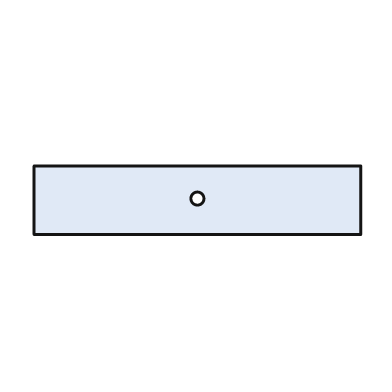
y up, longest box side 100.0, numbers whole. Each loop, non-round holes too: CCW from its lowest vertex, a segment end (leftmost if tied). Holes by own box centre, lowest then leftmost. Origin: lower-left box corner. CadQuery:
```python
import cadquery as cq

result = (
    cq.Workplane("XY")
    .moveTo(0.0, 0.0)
    .lineTo(100.0, 0.0)
    .lineTo(100.0, 21.0)
    .lineTo(0.0, 21.0)
    .close()
    .moveTo(50.0, 11.0)
    .circle(2.0)
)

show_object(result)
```